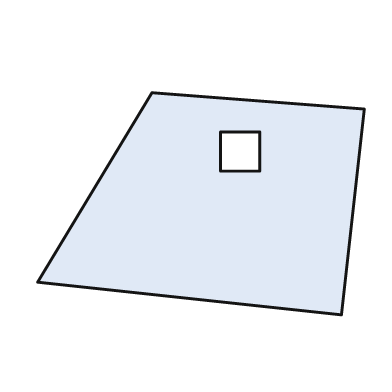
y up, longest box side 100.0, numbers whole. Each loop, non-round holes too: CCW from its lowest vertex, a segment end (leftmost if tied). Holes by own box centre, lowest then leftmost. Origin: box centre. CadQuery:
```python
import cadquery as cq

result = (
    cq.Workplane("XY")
    .moveTo(43.0, -34.0)
    .lineTo(50.0, 29.0)
    .lineTo(-15.0, 34.0)
    .lineTo(-50.0, -24.0)
    .close()
    .moveTo(6.0, 10.0)
    .lineTo(18.0, 10.0)
    .lineTo(18.0, 22.0)
    .lineTo(6.0, 22.0)
    .close()
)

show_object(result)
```